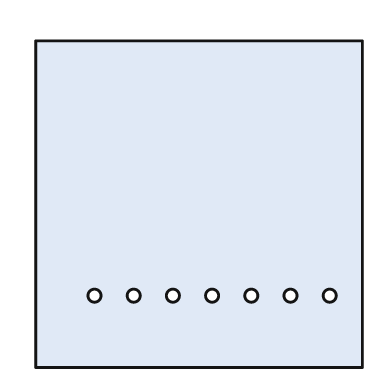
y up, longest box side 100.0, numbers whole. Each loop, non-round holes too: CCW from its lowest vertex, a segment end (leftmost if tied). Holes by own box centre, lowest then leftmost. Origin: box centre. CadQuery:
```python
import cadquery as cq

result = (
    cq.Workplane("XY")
    .moveTo(-50.0, -50.0)
    .lineTo(50.0, -50.0)
    .lineTo(50.0, 50.0)
    .lineTo(-50.0, 50.0)
    .close()
    .moveTo(-32.0, -28.0)
    .circle(2.0)
    .moveTo(-20.0, -28.0)
    .circle(2.0)
    .moveTo(-8.0, -28.0)
    .circle(2.0)
    .moveTo(4.0, -28.0)
    .circle(2.0)
    .moveTo(16.0, -28.0)
    .circle(2.0)
    .moveTo(28.0, -28.0)
    .circle(2.0)
    .moveTo(40.0, -28.0)
    .circle(2.0)
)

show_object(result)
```